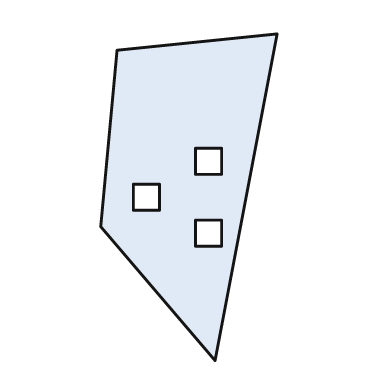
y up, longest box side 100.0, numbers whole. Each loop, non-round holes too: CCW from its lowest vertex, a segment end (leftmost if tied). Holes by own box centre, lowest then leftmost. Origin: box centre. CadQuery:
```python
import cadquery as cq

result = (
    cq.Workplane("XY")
    .moveTo(8.0, -50.0)
    .lineTo(27.0, 50.0)
    .lineTo(-22.0, 45.0)
    .lineTo(-27.0, -9.0)
    .close()
    .moveTo(2.0, -15.0)
    .lineTo(10.0, -15.0)
    .lineTo(10.0, -7.0)
    .lineTo(2.0, -7.0)
    .close()
    .moveTo(-17.0, -4.0)
    .lineTo(-9.0, -4.0)
    .lineTo(-9.0, 4.0)
    .lineTo(-17.0, 4.0)
    .close()
    .moveTo(2.0, 7.0)
    .lineTo(10.0, 7.0)
    .lineTo(10.0, 15.0)
    .lineTo(2.0, 15.0)
    .close()
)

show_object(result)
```